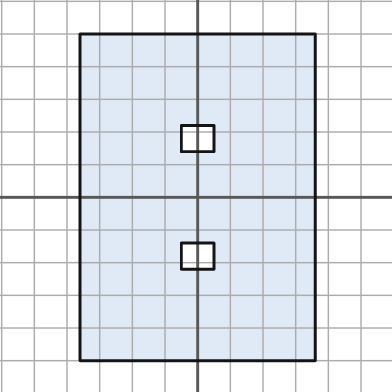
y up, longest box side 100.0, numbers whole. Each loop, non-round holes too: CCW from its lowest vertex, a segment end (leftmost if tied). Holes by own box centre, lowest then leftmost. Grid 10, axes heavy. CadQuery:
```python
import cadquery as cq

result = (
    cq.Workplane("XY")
    .moveTo(-36.0, -50.0)
    .lineTo(36.0, -50.0)
    .lineTo(36.0, 50.0)
    .lineTo(-36.0, 50.0)
    .close()
    .moveTo(-5.0, -22.0)
    .lineTo(5.0, -22.0)
    .lineTo(5.0, -14.0)
    .lineTo(-5.0, -14.0)
    .close()
    .moveTo(-5.0, 14.0)
    .lineTo(5.0, 14.0)
    .lineTo(5.0, 22.0)
    .lineTo(-5.0, 22.0)
    .close()
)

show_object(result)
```